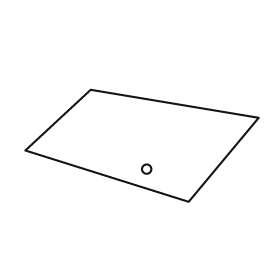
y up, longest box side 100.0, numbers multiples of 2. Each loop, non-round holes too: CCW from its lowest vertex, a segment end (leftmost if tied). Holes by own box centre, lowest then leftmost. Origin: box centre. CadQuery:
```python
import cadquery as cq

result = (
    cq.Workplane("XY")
    .moveTo(20.0, -24.0)
    .lineTo(50.0, 12.0)
    .lineTo(-22.0, 24.0)
    .lineTo(-50.0, -2.0)
    .close()
    .moveTo(2.0, -10.0)
    .circle(2.0)
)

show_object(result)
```